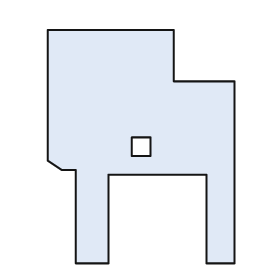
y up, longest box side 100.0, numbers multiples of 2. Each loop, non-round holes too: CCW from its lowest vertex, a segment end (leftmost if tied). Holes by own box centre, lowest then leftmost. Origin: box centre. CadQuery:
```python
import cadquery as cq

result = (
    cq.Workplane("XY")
    .moveTo(-28.0, -50.0)
    .lineTo(-14.0, -50.0)
    .lineTo(-14.0, -12.0)
    .lineTo(28.0, -12.0)
    .lineTo(28.0, -50.0)
    .lineTo(40.0, -50.0)
    .lineTo(40.0, 28.0)
    .lineTo(14.0, 28.0)
    .lineTo(14.0, 50.0)
    .lineTo(-40.0, 50.0)
    .lineTo(-40.0, -6.0)
    .lineTo(-34.0, -10.0)
    .lineTo(-28.0, -10.0)
    .close()
    .moveTo(-4.0, -4.0)
    .lineTo(4.0, -4.0)
    .lineTo(4.0, 4.0)
    .lineTo(-4.0, 4.0)
    .close()
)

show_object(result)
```